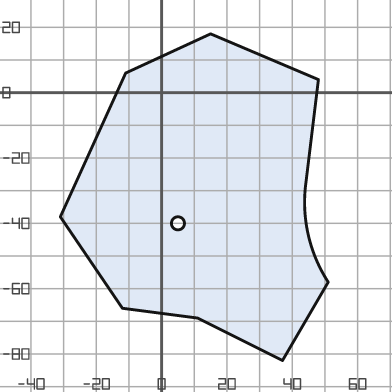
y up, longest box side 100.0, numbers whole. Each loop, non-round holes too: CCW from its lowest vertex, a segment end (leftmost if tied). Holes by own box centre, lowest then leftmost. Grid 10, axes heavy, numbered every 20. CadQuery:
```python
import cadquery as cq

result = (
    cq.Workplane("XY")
    .moveTo(37.0, -82.0)
    .lineTo(51.0, -58.0)
    .threePointArc((45.0, -44.0), (44.0, -29.0))
    .lineTo(48.0, 4.0)
    .lineTo(15.0, 18.0)
    .lineTo(-11.0, 6.0)
    .lineTo(-31.0, -38.0)
    .lineTo(-12.0, -66.0)
    .lineTo(11.0, -69.0)
    .close()
    .moveTo(5.0, -40.0)
    .circle(2.0)
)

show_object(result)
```